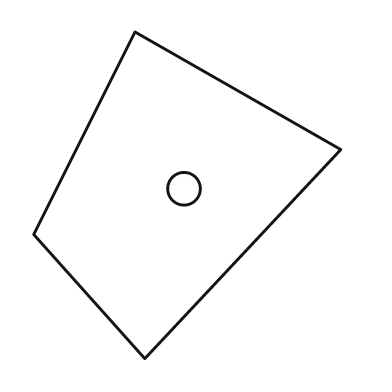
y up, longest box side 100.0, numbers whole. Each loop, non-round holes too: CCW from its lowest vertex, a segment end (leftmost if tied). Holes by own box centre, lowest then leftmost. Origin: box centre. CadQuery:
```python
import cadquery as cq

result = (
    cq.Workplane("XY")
    .moveTo(-13.0, -50.0)
    .lineTo(47.0, 14.0)
    .lineTo(-16.0, 50.0)
    .lineTo(-47.0, -12.0)
    .close()
    .moveTo(-1.0, 2.0)
    .circle(5.0)
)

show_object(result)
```